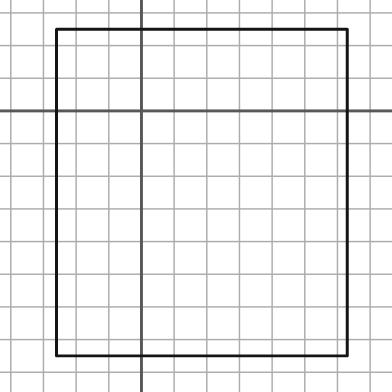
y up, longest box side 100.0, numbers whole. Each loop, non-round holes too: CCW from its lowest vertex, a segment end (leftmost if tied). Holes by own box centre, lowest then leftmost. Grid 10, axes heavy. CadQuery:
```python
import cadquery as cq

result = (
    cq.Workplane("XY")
    .moveTo(-26.0, -75.0)
    .lineTo(63.0, -75.0)
    .lineTo(63.0, 25.0)
    .lineTo(-26.0, 25.0)
    .close()
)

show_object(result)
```